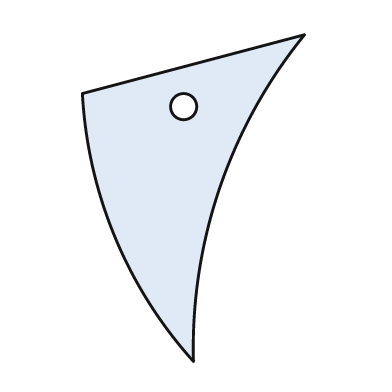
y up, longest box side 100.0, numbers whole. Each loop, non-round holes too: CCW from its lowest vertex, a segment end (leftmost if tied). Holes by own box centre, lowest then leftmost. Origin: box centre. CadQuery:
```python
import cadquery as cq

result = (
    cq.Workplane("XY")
    .moveTo(0.0, -50.0)
    .threePointArc((8.0, 3.0), (34.0, 50.0))
    .lineTo(-34.0, 32.0)
    .threePointArc((-24.0, -12.0), (0.0, -50.0))
    .close()
    .moveTo(-3.0, 28.0)
    .circle(4.0)
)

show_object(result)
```